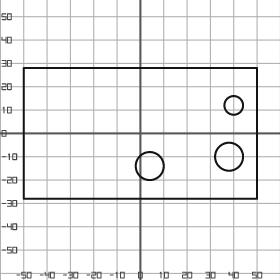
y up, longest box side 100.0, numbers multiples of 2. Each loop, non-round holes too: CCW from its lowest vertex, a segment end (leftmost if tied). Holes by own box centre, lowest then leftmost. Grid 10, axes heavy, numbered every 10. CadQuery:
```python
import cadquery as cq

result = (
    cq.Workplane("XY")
    .moveTo(-50.0, -28.0)
    .lineTo(50.0, -28.0)
    .lineTo(50.0, 28.0)
    .lineTo(-50.0, 28.0)
    .close()
    .moveTo(4.0, -14.0)
    .circle(6.0)
    .moveTo(38.0, -10.0)
    .circle(6.0)
    .moveTo(40.0, 12.0)
    .circle(4.0)
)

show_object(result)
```